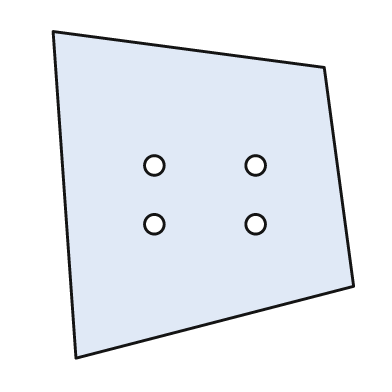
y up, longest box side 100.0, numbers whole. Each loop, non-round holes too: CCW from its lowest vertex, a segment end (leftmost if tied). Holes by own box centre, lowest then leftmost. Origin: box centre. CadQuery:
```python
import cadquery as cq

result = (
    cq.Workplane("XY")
    .moveTo(-39.0, -50.0)
    .lineTo(46.0, -28.0)
    .lineTo(37.0, 39.0)
    .lineTo(-46.0, 50.0)
    .close()
    .moveTo(-15.0, -9.0)
    .circle(3.0)
    .moveTo(16.0, -9.0)
    .circle(3.0)
    .moveTo(-15.0, 9.0)
    .circle(3.0)
    .moveTo(16.0, 9.0)
    .circle(3.0)
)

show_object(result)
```